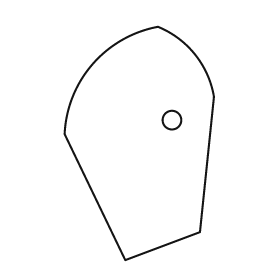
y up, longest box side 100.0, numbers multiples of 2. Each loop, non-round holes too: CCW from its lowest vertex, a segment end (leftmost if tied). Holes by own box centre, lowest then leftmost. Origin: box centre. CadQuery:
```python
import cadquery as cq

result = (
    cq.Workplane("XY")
    .moveTo(-6.0, -50.0)
    .lineTo(26.0, -38.0)
    .lineTo(32.0, 20.0)
    .threePointArc((24.0, 38.0), (8.0, 50.0))
    .threePointArc((-20.0, 34.0), (-32.0, 4.0))
    .close()
    .moveTo(14.0, 10.0)
    .circle(4.0)
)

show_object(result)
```